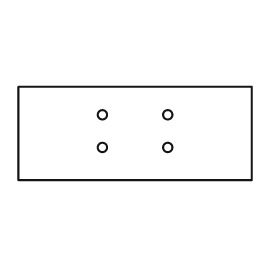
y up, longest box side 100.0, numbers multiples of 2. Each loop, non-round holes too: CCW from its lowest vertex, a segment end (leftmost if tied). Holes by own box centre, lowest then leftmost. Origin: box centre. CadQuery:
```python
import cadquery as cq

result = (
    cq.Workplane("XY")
    .moveTo(-50.0, -20.0)
    .lineTo(50.0, -20.0)
    .lineTo(50.0, 20.0)
    .lineTo(-50.0, 20.0)
    .close()
    .moveTo(-14.0, -6.0)
    .circle(2.0)
    .moveTo(14.0, -6.0)
    .circle(2.0)
    .moveTo(-14.0, 8.0)
    .circle(2.0)
    .moveTo(14.0, 8.0)
    .circle(2.0)
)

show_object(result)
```